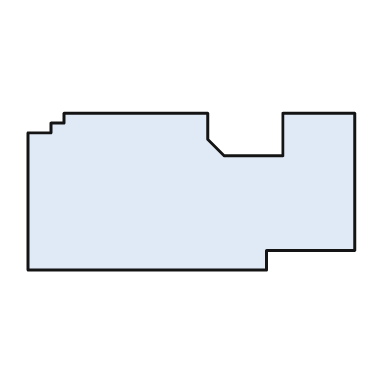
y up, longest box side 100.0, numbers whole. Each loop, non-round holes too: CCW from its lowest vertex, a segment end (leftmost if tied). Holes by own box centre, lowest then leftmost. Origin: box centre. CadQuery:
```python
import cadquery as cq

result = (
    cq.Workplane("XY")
    .moveTo(-50.0, -24.0)
    .lineTo(23.0, -24.0)
    .lineTo(23.0, -18.0)
    .lineTo(50.0, -18.0)
    .lineTo(50.0, 24.0)
    .lineTo(28.0, 24.0)
    .lineTo(28.0, 11.0)
    .lineTo(10.0, 11.0)
    .lineTo(5.0, 16.0)
    .lineTo(5.0, 24.0)
    .lineTo(-39.0, 24.0)
    .lineTo(-39.0, 21.0)
    .lineTo(-43.0, 21.0)
    .lineTo(-43.0, 18.0)
    .lineTo(-50.0, 18.0)
    .close()
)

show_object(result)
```